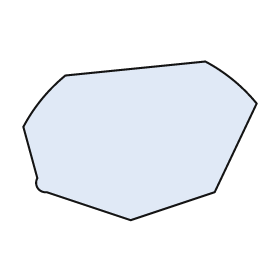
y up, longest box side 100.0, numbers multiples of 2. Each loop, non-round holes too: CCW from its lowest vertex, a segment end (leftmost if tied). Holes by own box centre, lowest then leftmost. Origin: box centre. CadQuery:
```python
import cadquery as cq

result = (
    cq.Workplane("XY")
    .moveTo(-4.0, -34.0)
    .lineTo(32.0, -22.0)
    .lineTo(50.0, 16.0)
    .threePointArc((40.0, 26.0), (28.0, 34.0))
    .lineTo(-32.0, 28.0)
    .threePointArc((-42.0, 18.0), (-50.0, 6.0))
    .lineTo(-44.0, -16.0)
    .threePointArc((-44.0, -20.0), (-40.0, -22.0))
    .close()
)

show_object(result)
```